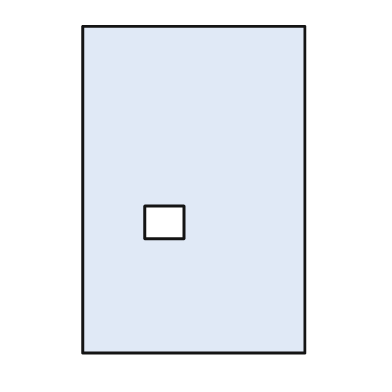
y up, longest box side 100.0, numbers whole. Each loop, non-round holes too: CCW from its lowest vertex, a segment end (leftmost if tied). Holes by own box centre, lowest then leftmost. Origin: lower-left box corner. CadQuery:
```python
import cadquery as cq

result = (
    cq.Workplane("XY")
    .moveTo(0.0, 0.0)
    .lineTo(68.0, 0.0)
    .lineTo(68.0, 100.0)
    .lineTo(0.0, 100.0)
    .close()
    .moveTo(19.0, 35.0)
    .lineTo(31.0, 35.0)
    .lineTo(31.0, 45.0)
    .lineTo(19.0, 45.0)
    .close()
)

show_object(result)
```